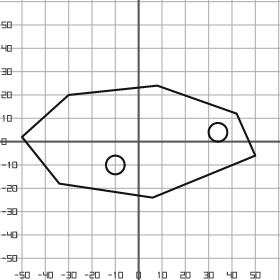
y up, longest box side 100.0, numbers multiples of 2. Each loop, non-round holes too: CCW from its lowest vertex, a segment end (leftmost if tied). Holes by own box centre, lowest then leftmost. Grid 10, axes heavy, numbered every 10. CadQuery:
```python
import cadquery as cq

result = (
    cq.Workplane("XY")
    .moveTo(6.0, -24.0)
    .lineTo(50.0, -6.0)
    .lineTo(42.0, 12.0)
    .lineTo(8.0, 24.0)
    .lineTo(-30.0, 20.0)
    .lineTo(-50.0, 2.0)
    .lineTo(-34.0, -18.0)
    .close()
    .moveTo(-10.0, -10.0)
    .circle(4.0)
    .moveTo(34.0, 4.0)
    .circle(4.0)
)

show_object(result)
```